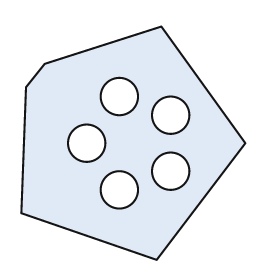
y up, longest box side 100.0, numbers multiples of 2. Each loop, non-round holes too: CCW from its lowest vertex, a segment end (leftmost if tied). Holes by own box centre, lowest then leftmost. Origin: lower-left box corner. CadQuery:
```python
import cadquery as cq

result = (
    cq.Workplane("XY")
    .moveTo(58.0, 0.0)
    .lineTo(96.0, 50.0)
    .lineTo(60.0, 100.0)
    .lineTo(10.0, 84.0)
    .lineTo(2.0, 74.0)
    .lineTo(0.0, 20.0)
    .close()
    .moveTo(42.0, 30.0)
    .circle(8.0)
    .moveTo(64.0, 38.0)
    .circle(8.0)
    .moveTo(28.0, 50.0)
    .circle(8.0)
    .moveTo(64.0, 62.0)
    .circle(8.0)
    .moveTo(42.0, 70.0)
    .circle(8.0)
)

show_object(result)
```